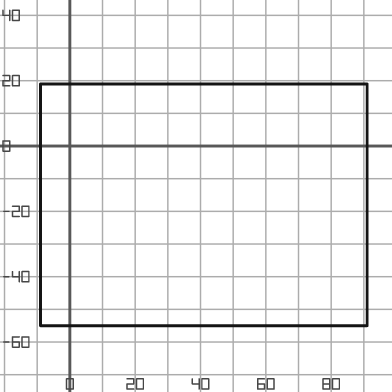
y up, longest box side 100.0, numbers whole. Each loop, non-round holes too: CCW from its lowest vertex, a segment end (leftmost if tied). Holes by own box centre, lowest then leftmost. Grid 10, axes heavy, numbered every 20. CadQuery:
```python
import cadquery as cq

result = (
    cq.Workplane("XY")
    .moveTo(-9.0, -55.0)
    .lineTo(91.0, -55.0)
    .lineTo(91.0, 19.0)
    .lineTo(-9.0, 19.0)
    .close()
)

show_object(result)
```